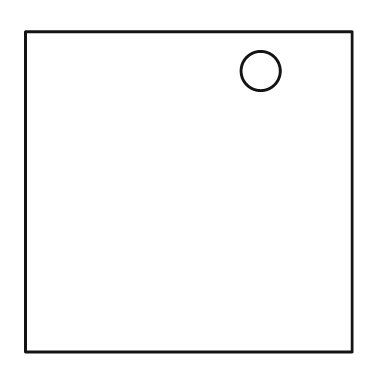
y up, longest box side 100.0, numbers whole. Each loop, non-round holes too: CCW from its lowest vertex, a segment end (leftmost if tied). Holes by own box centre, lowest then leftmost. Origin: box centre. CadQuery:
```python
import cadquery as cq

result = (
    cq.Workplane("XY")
    .moveTo(-50.0, -49.0)
    .lineTo(50.0, -49.0)
    .lineTo(50.0, 49.0)
    .lineTo(-50.0, 49.0)
    .close()
    .moveTo(22.0, 37.0)
    .circle(6.0)
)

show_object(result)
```